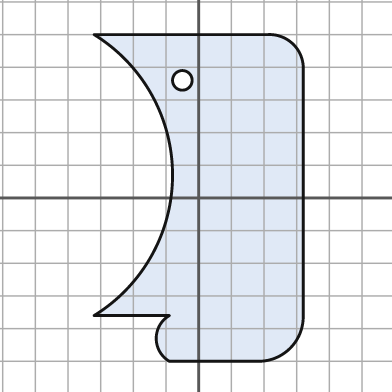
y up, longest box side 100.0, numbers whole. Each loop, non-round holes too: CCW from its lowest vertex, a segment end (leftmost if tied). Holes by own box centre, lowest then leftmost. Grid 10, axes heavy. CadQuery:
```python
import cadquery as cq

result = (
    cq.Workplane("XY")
    .moveTo(-9.0, -50.0)
    .lineTo(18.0, -50.0)
    .threePointArc((28.0, -46.0), (32.0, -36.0))
    .lineTo(32.0, 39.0)
    .threePointArc((29.0, 47.0), (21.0, 50.0))
    .lineTo(-32.0, 50.0)
    .threePointArc((-8.0, 7.0), (-32.0, -36.0))
    .lineTo(-9.0, -36.0)
    .threePointArc((-13.0, -43.0), (-9.0, -50.0))
    .close()
    .moveTo(-5.0, 36.0)
    .circle(3.0)
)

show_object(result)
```